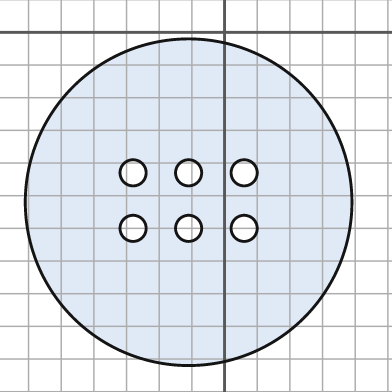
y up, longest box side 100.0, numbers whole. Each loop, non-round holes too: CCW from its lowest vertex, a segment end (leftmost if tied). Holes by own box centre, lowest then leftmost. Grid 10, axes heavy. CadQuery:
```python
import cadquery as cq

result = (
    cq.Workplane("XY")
    .moveTo(-11.0, -52.0)
    .circle(50.0)
    .moveTo(-28.0, -60.0)
    .circle(4.0)
    .moveTo(-11.0, -60.0)
    .circle(4.0)
    .moveTo(6.0, -60.0)
    .circle(4.0)
    .moveTo(-28.0, -43.0)
    .circle(4.0)
    .moveTo(-11.0, -43.0)
    .circle(4.0)
    .moveTo(6.0, -43.0)
    .circle(4.0)
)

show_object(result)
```